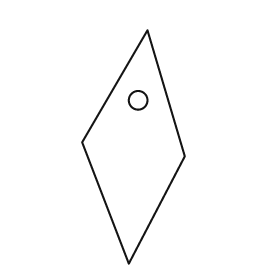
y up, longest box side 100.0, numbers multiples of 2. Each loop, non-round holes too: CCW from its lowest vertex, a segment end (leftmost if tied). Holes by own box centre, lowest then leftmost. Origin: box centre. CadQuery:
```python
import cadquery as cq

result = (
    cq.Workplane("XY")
    .moveTo(-2.0, -50.0)
    .lineTo(22.0, -4.0)
    .lineTo(6.0, 50.0)
    .lineTo(-22.0, 2.0)
    .close()
    .moveTo(2.0, 20.0)
    .circle(4.0)
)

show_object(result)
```